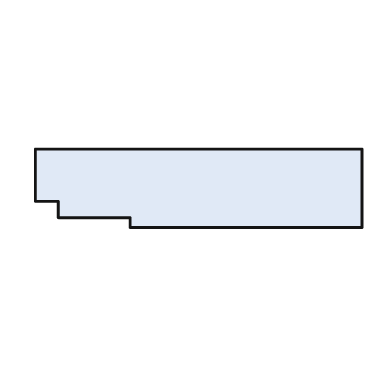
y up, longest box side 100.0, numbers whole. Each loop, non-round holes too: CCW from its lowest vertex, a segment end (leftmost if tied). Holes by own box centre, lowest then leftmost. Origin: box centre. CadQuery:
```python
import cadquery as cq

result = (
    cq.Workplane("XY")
    .moveTo(-21.0, -12.0)
    .lineTo(50.0, -12.0)
    .lineTo(50.0, 12.0)
    .lineTo(-50.0, 12.0)
    .lineTo(-50.0, -4.0)
    .lineTo(-43.0, -4.0)
    .lineTo(-43.0, -9.0)
    .lineTo(-21.0, -9.0)
    .close()
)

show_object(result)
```